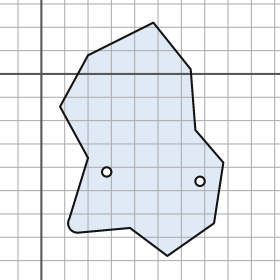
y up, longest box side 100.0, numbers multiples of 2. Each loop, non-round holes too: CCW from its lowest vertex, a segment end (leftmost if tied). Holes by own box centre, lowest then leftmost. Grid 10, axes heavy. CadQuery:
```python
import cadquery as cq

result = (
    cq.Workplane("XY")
    .moveTo(54.0, -78.0)
    .lineTo(74.0, -64.0)
    .lineTo(78.0, -38.0)
    .lineTo(66.0, -24.0)
    .lineTo(64.0, 2.0)
    .lineTo(48.0, 22.0)
    .lineTo(20.0, 8.0)
    .lineTo(8.0, -14.0)
    .lineTo(20.0, -36.0)
    .lineTo(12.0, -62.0)
    .threePointArc((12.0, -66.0), (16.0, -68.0))
    .lineTo(38.0, -66.0)
    .close()
    .moveTo(68.0, -46.0)
    .circle(2.0)
    .moveTo(28.0, -42.0)
    .circle(2.0)
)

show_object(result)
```